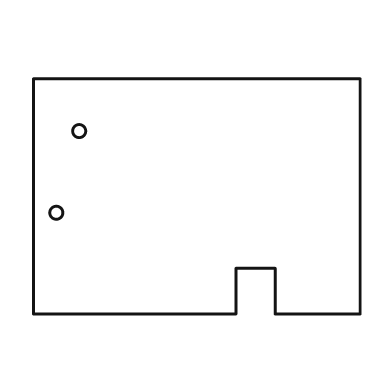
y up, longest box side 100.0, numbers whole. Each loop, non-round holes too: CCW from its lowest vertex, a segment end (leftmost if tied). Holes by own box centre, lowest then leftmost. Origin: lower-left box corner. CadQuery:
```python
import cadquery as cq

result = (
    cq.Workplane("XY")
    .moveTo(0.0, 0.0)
    .lineTo(62.0, 0.0)
    .lineTo(62.0, 14.0)
    .lineTo(74.0, 14.0)
    .lineTo(74.0, 0.0)
    .lineTo(100.0, 0.0)
    .lineTo(100.0, 72.0)
    .lineTo(0.0, 72.0)
    .close()
    .moveTo(7.0, 31.0)
    .circle(2.0)
    .moveTo(14.0, 56.0)
    .circle(2.0)
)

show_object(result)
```